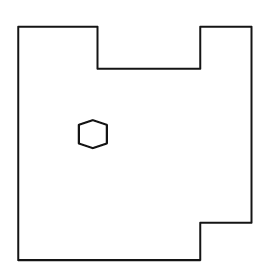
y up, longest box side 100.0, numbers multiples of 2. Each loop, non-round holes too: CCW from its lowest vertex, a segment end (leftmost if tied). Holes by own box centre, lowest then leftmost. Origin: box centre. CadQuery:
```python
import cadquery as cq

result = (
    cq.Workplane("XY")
    .moveTo(-50.0, -50.0)
    .lineTo(28.0, -50.0)
    .lineTo(28.0, -34.0)
    .lineTo(50.0, -34.0)
    .lineTo(50.0, 50.0)
    .lineTo(28.0, 50.0)
    .lineTo(28.0, 32.0)
    .lineTo(-16.0, 32.0)
    .lineTo(-16.0, 50.0)
    .lineTo(-50.0, 50.0)
    .close()
    .moveTo(-18.0, -2.0)
    .lineTo(-12.0, 0.0)
    .lineTo(-12.0, 8.0)
    .lineTo(-18.0, 10.0)
    .lineTo(-24.0, 8.0)
    .lineTo(-24.0, 0.0)
    .close()
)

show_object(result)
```